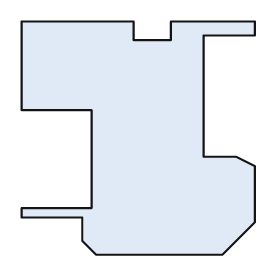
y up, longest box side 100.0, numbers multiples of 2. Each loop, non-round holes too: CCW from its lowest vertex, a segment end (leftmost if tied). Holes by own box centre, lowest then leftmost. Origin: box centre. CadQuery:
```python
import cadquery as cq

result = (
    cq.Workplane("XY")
    .moveTo(-18.0, -50.0)
    .lineTo(36.0, -50.0)
    .lineTo(50.0, -36.0)
    .lineTo(50.0, -12.0)
    .lineTo(42.0, -8.0)
    .lineTo(28.0, -8.0)
    .lineTo(28.0, 44.0)
    .lineTo(50.0, 44.0)
    .lineTo(50.0, 50.0)
    .lineTo(14.0, 50.0)
    .lineTo(14.0, 42.0)
    .lineTo(-2.0, 42.0)
    .lineTo(-2.0, 50.0)
    .lineTo(-50.0, 50.0)
    .lineTo(-50.0, 12.0)
    .lineTo(-20.0, 12.0)
    .lineTo(-20.0, -30.0)
    .lineTo(-50.0, -30.0)
    .lineTo(-50.0, -34.0)
    .lineTo(-24.0, -34.0)
    .lineTo(-24.0, -44.0)
    .close()
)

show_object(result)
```